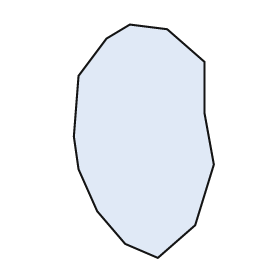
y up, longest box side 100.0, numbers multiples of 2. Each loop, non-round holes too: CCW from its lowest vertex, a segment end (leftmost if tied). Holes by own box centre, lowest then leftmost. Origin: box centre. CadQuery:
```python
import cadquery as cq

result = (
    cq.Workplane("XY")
    .moveTo(6.0, -50.0)
    .lineTo(22.0, -36.0)
    .lineTo(30.0, -10.0)
    .lineTo(26.0, 12.0)
    .lineTo(26.0, 34.0)
    .lineTo(10.0, 48.0)
    .lineTo(-6.0, 50.0)
    .lineTo(-16.0, 44.0)
    .lineTo(-28.0, 28.0)
    .lineTo(-30.0, 2.0)
    .lineTo(-28.0, -12.0)
    .lineTo(-20.0, -30.0)
    .lineTo(-8.0, -44.0)
    .close()
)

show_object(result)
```